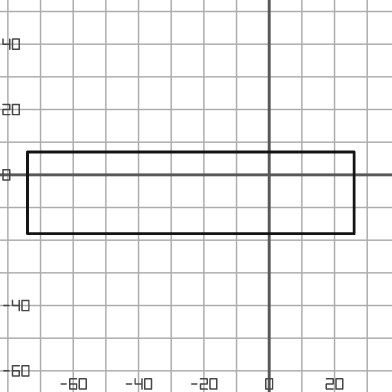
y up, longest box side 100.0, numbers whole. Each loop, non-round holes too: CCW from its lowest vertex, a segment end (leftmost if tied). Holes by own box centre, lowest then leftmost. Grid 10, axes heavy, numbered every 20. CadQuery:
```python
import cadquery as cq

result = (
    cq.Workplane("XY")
    .moveTo(-74.0, -18.0)
    .lineTo(26.0, -18.0)
    .lineTo(26.0, 7.0)
    .lineTo(-74.0, 7.0)
    .close()
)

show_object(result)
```